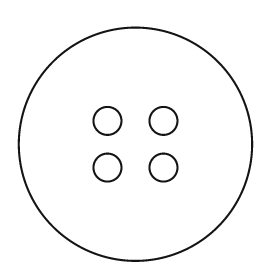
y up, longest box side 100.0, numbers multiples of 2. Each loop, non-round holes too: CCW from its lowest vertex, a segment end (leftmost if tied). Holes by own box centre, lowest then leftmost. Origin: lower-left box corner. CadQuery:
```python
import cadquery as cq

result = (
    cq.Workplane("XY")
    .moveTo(50.0, 50.0)
    .circle(50.0)
    .moveTo(38.0, 40.0)
    .circle(6.0)
    .moveTo(62.0, 40.0)
    .circle(6.0)
    .moveTo(38.0, 60.0)
    .circle(6.0)
    .moveTo(62.0, 60.0)
    .circle(6.0)
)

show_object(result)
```